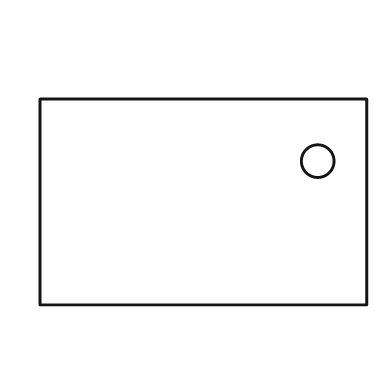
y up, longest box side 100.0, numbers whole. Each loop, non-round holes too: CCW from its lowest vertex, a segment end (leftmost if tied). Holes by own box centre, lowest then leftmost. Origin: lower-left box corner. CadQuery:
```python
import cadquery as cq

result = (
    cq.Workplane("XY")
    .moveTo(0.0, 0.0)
    .lineTo(100.0, 0.0)
    .lineTo(100.0, 63.0)
    .lineTo(0.0, 63.0)
    .close()
    .moveTo(85.0, 44.0)
    .circle(5.0)
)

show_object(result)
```